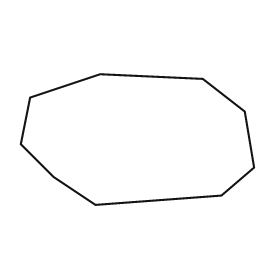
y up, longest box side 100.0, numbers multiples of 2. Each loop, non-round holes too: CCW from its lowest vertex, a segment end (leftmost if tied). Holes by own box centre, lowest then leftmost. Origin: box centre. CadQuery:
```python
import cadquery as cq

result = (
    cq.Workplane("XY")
    .moveTo(-18.0, -28.0)
    .lineTo(36.0, -24.0)
    .lineTo(50.0, -12.0)
    .lineTo(46.0, 12.0)
    .lineTo(28.0, 26.0)
    .lineTo(-16.0, 28.0)
    .lineTo(-46.0, 18.0)
    .lineTo(-50.0, -2.0)
    .lineTo(-36.0, -16.0)
    .close()
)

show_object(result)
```